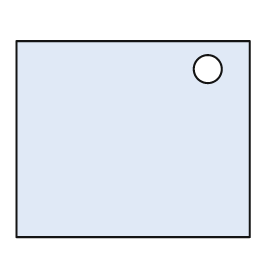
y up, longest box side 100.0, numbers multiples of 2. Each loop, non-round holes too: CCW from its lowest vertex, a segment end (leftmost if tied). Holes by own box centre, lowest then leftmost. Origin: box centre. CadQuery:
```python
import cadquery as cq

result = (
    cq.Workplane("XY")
    .moveTo(-50.0, -42.0)
    .lineTo(50.0, -42.0)
    .lineTo(50.0, 42.0)
    .lineTo(-50.0, 42.0)
    .close()
    .moveTo(32.0, 30.0)
    .circle(6.0)
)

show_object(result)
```